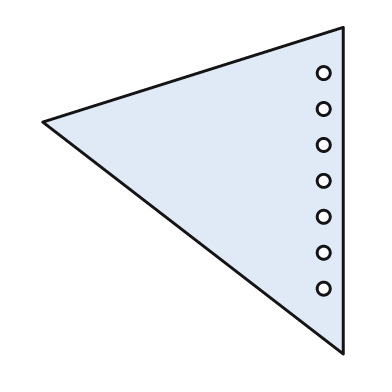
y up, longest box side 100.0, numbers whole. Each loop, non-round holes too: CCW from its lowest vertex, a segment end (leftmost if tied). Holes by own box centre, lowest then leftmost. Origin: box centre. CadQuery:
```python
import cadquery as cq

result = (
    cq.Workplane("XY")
    .moveTo(46.0, -50.0)
    .lineTo(46.0, 50.0)
    .lineTo(-46.0, 21.0)
    .close()
    .moveTo(40.0, -30.0)
    .circle(2.0)
    .moveTo(40.0, -19.0)
    .circle(2.0)
    .moveTo(40.0, -8.0)
    .circle(2.0)
    .moveTo(40.0, 3.0)
    .circle(2.0)
    .moveTo(40.0, 14.0)
    .circle(2.0)
    .moveTo(40.0, 25.0)
    .circle(2.0)
    .moveTo(40.0, 36.0)
    .circle(2.0)
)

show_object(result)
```